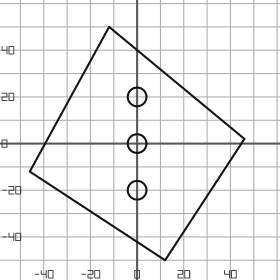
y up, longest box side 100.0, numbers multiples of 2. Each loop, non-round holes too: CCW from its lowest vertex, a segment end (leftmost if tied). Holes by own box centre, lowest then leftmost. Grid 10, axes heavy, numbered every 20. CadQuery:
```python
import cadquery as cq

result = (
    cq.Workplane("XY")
    .moveTo(12.0, -50.0)
    .lineTo(46.0, 2.0)
    .lineTo(-12.0, 50.0)
    .lineTo(-46.0, -12.0)
    .close()
    .moveTo(0.0, -20.0)
    .circle(4.0)
    .moveTo(0.0, 0.0)
    .circle(4.0)
    .moveTo(0.0, 20.0)
    .circle(4.0)
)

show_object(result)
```